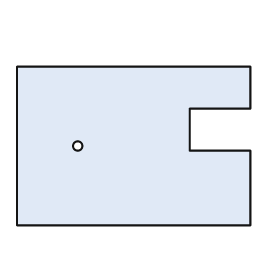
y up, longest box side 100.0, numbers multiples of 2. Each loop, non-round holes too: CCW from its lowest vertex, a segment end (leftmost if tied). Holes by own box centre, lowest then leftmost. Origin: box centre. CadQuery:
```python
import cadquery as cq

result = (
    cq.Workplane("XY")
    .moveTo(-50.0, -34.0)
    .lineTo(50.0, -34.0)
    .lineTo(50.0, -2.0)
    .lineTo(24.0, -2.0)
    .lineTo(24.0, 16.0)
    .lineTo(50.0, 16.0)
    .lineTo(50.0, 34.0)
    .lineTo(-50.0, 34.0)
    .close()
    .moveTo(-24.0, 0.0)
    .circle(2.0)
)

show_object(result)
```